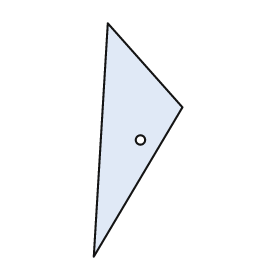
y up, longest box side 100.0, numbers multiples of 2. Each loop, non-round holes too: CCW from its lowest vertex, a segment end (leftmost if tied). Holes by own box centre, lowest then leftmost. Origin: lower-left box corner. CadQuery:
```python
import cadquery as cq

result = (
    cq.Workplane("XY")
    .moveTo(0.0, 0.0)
    .lineTo(38.0, 64.0)
    .lineTo(6.0, 100.0)
    .close()
    .moveTo(20.0, 50.0)
    .circle(2.0)
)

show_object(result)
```